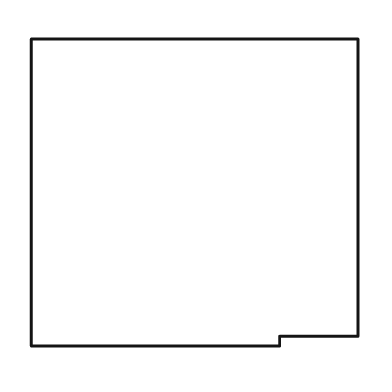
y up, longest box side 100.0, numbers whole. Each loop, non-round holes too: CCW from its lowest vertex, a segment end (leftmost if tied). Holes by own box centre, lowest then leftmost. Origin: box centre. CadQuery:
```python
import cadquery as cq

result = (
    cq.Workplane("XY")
    .moveTo(-50.0, -47.0)
    .lineTo(26.0, -47.0)
    .lineTo(26.0, -44.0)
    .lineTo(50.0, -44.0)
    .lineTo(50.0, 47.0)
    .lineTo(-50.0, 47.0)
    .close()
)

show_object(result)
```